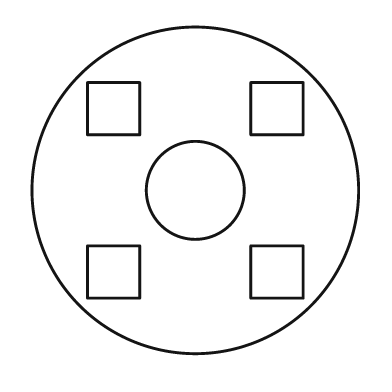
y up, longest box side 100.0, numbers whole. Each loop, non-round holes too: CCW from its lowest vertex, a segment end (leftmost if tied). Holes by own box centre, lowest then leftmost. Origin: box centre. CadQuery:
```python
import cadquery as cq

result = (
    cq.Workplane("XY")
    .moveTo(0.0, 0.0)
    .circle(50.0)
    .moveTo(-33.0, -33.0)
    .lineTo(-17.0, -33.0)
    .lineTo(-17.0, -17.0)
    .lineTo(-33.0, -17.0)
    .close()
    .moveTo(17.0, -33.0)
    .lineTo(33.0, -33.0)
    .lineTo(33.0, -17.0)
    .lineTo(17.0, -17.0)
    .close()
    .moveTo(0.0, 0.0)
    .circle(15.0)
    .moveTo(-33.0, 17.0)
    .lineTo(-17.0, 17.0)
    .lineTo(-17.0, 33.0)
    .lineTo(-33.0, 33.0)
    .close()
    .moveTo(17.0, 17.0)
    .lineTo(33.0, 17.0)
    .lineTo(33.0, 33.0)
    .lineTo(17.0, 33.0)
    .close()
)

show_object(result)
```